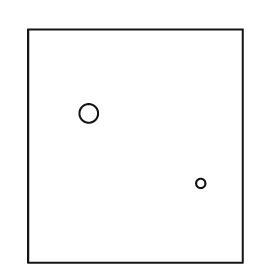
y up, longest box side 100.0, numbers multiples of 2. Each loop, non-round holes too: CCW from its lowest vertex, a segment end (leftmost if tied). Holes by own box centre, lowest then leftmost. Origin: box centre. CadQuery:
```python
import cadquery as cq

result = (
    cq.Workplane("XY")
    .moveTo(-46.0, -50.0)
    .lineTo(46.0, -50.0)
    .lineTo(46.0, 50.0)
    .lineTo(-46.0, 50.0)
    .close()
    .moveTo(28.0, -16.0)
    .circle(2.0)
    .moveTo(-20.0, 14.0)
    .circle(4.0)
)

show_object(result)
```